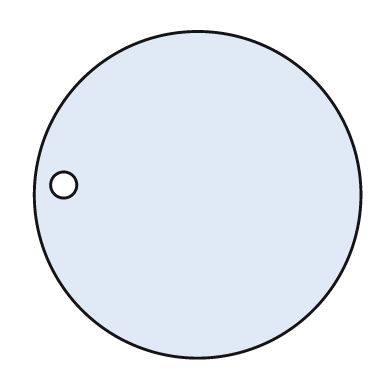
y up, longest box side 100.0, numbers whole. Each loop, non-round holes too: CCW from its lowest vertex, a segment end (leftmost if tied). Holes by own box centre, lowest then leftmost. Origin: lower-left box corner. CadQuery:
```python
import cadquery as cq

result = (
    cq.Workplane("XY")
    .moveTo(50.0, 50.0)
    .circle(50.0)
    .moveTo(9.0, 53.0)
    .circle(4.0)
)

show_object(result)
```